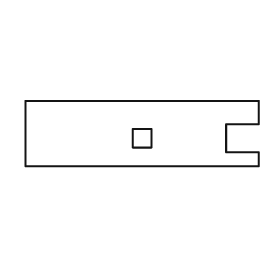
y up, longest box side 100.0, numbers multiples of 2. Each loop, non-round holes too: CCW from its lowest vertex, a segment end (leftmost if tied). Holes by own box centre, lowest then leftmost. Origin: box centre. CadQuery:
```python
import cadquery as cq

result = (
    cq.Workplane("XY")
    .moveTo(-50.0, -14.0)
    .lineTo(50.0, -14.0)
    .lineTo(50.0, -8.0)
    .lineTo(36.0, -8.0)
    .lineTo(36.0, 4.0)
    .lineTo(50.0, 4.0)
    .lineTo(50.0, 14.0)
    .lineTo(-50.0, 14.0)
    .close()
    .moveTo(-4.0, -6.0)
    .lineTo(4.0, -6.0)
    .lineTo(4.0, 2.0)
    .lineTo(-4.0, 2.0)
    .close()
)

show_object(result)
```